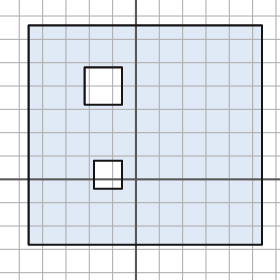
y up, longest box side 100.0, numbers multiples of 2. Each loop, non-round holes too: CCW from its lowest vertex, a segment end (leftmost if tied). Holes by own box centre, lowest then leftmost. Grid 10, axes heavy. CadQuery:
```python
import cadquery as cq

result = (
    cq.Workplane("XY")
    .moveTo(-46.0, -28.0)
    .lineTo(54.0, -28.0)
    .lineTo(54.0, 66.0)
    .lineTo(-46.0, 66.0)
    .close()
    .moveTo(-18.0, -4.0)
    .lineTo(-6.0, -4.0)
    .lineTo(-6.0, 8.0)
    .lineTo(-18.0, 8.0)
    .close()
    .moveTo(-22.0, 32.0)
    .lineTo(-6.0, 32.0)
    .lineTo(-6.0, 48.0)
    .lineTo(-22.0, 48.0)
    .close()
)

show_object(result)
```